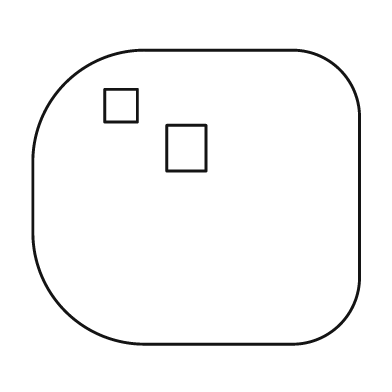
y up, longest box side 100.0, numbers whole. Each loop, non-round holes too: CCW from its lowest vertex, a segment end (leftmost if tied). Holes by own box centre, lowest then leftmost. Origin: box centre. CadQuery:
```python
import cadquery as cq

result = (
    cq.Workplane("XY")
    .moveTo(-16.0, -45.0)
    .lineTo(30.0, -45.0)
    .threePointArc((44.0, -39.0), (50.0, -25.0))
    .lineTo(50.0, 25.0)
    .threePointArc((44.0, 39.0), (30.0, 45.0))
    .lineTo(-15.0, 45.0)
    .threePointArc((-40.0, 35.0), (-50.0, 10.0))
    .lineTo(-50.0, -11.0)
    .threePointArc((-40.0, -35.0), (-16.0, -45.0))
    .close()
    .moveTo(-9.0, 8.0)
    .lineTo(3.0, 8.0)
    .lineTo(3.0, 22.0)
    .lineTo(-9.0, 22.0)
    .close()
    .moveTo(-28.0, 23.0)
    .lineTo(-18.0, 23.0)
    .lineTo(-18.0, 33.0)
    .lineTo(-28.0, 33.0)
    .close()
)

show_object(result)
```